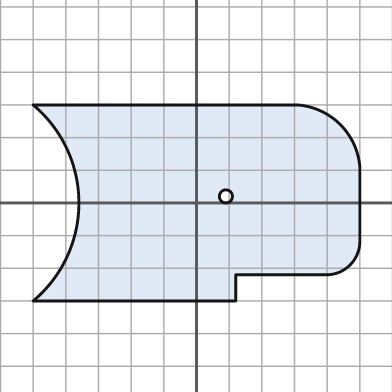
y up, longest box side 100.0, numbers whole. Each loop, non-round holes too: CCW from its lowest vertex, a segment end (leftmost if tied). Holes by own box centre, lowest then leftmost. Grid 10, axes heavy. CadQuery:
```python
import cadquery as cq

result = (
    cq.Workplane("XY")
    .moveTo(-50.0, -30.0)
    .lineTo(12.0, -30.0)
    .lineTo(12.0, -22.0)
    .lineTo(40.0, -22.0)
    .threePointArc((47.0, -19.0), (50.0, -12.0))
    .lineTo(50.0, 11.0)
    .threePointArc((44.0, 24.0), (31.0, 30.0))
    .lineTo(-50.0, 30.0)
    .threePointArc((-36.0, 0.0), (-50.0, -30.0))
    .close()
    .moveTo(9.0, 2.0)
    .circle(2.0)
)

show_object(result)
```